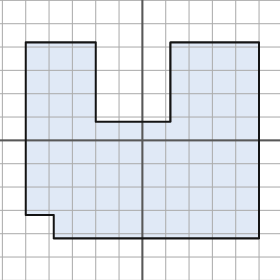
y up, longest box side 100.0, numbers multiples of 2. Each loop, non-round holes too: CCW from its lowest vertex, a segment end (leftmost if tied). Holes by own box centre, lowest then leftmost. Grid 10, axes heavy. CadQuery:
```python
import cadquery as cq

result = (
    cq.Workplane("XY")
    .moveTo(-38.0, -42.0)
    .lineTo(50.0, -42.0)
    .lineTo(50.0, 42.0)
    .lineTo(12.0, 42.0)
    .lineTo(12.0, 8.0)
    .lineTo(-20.0, 8.0)
    .lineTo(-20.0, 42.0)
    .lineTo(-50.0, 42.0)
    .lineTo(-50.0, -32.0)
    .lineTo(-38.0, -32.0)
    .close()
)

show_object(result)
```